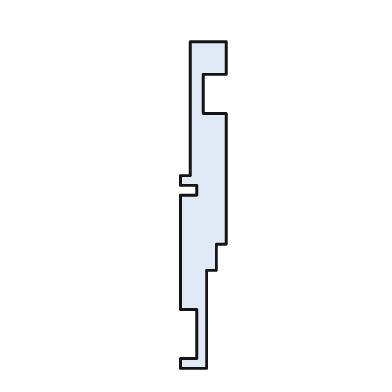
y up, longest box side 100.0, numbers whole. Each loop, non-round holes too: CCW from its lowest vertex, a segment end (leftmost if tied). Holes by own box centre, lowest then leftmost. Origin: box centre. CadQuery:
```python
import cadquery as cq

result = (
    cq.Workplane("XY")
    .moveTo(-7.0, -50.0)
    .lineTo(1.0, -50.0)
    .lineTo(1.0, -20.0)
    .lineTo(4.0, -20.0)
    .lineTo(4.0, -12.0)
    .lineTo(7.0, -12.0)
    .lineTo(7.0, 28.0)
    .lineTo(0.0, 28.0)
    .lineTo(0.0, 40.0)
    .lineTo(7.0, 40.0)
    .lineTo(7.0, 50.0)
    .lineTo(-4.0, 50.0)
    .lineTo(-4.0, 9.0)
    .lineTo(-7.0, 9.0)
    .lineTo(-7.0, 6.0)
    .lineTo(-2.0, 6.0)
    .lineTo(-2.0, 3.0)
    .lineTo(-7.0, 3.0)
    .lineTo(-7.0, -32.0)
    .lineTo(-2.0, -32.0)
    .lineTo(-2.0, -47.0)
    .lineTo(-7.0, -47.0)
    .close()
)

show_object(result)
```